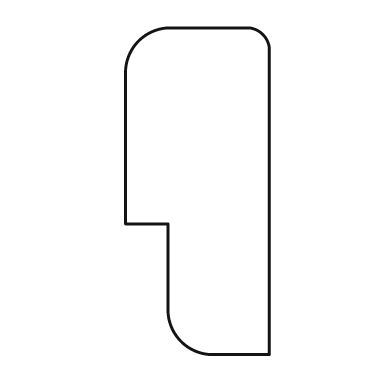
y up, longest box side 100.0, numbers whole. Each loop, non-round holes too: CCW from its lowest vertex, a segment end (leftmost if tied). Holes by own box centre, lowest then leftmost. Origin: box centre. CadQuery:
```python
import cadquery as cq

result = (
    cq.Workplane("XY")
    .moveTo(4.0, -50.0)
    .lineTo(22.0, -50.0)
    .lineTo(22.0, 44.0)
    .threePointArc((20.0, 48.0), (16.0, 50.0))
    .lineTo(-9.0, 50.0)
    .threePointArc((-18.0, 46.0), (-22.0, 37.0))
    .lineTo(-22.0, -10.0)
    .lineTo(-9.0, -10.0)
    .lineTo(-9.0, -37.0)
    .threePointArc((-5.0, -46.0), (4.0, -50.0))
    .close()
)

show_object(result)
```